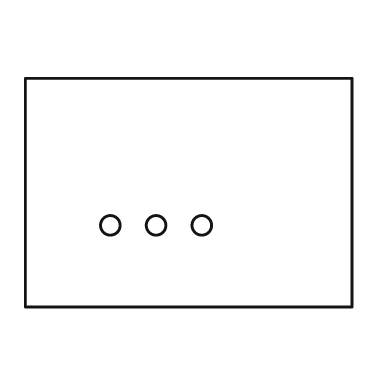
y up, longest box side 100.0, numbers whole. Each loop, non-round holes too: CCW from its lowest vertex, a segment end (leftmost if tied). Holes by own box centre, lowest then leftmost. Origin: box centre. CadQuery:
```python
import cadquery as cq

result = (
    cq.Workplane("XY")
    .moveTo(-50.0, -35.0)
    .lineTo(50.0, -35.0)
    .lineTo(50.0, 35.0)
    .lineTo(-50.0, 35.0)
    .close()
    .moveTo(-24.0, -10.0)
    .circle(3.0)
    .moveTo(-10.0, -10.0)
    .circle(3.0)
    .moveTo(4.0, -10.0)
    .circle(3.0)
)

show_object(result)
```